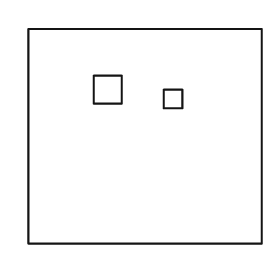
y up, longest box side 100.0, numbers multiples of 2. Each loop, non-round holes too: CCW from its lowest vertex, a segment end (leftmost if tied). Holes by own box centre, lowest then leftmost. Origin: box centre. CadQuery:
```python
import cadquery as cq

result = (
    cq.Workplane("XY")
    .moveTo(-50.0, -46.0)
    .lineTo(50.0, -46.0)
    .lineTo(50.0, 46.0)
    .lineTo(-50.0, 46.0)
    .close()
    .moveTo(8.0, 12.0)
    .lineTo(16.0, 12.0)
    .lineTo(16.0, 20.0)
    .lineTo(8.0, 20.0)
    .close()
    .moveTo(-22.0, 14.0)
    .lineTo(-10.0, 14.0)
    .lineTo(-10.0, 26.0)
    .lineTo(-22.0, 26.0)
    .close()
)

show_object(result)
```